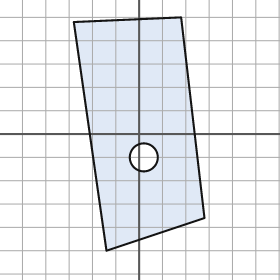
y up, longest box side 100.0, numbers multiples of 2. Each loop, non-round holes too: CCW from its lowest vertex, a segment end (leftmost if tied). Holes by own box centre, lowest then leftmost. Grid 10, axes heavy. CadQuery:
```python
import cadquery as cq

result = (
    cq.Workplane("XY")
    .moveTo(-14.0, -50.0)
    .lineTo(28.0, -36.0)
    .lineTo(18.0, 50.0)
    .lineTo(-28.0, 48.0)
    .close()
    .moveTo(2.0, -10.0)
    .circle(6.0)
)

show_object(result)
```